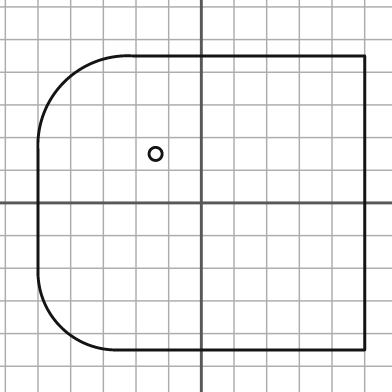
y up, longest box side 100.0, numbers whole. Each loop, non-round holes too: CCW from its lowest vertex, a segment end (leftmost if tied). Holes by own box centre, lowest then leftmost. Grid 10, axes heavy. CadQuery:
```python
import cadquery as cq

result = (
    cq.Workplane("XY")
    .moveTo(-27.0, -45.0)
    .lineTo(50.0, -45.0)
    .lineTo(50.0, 45.0)
    .lineTo(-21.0, 45.0)
    .threePointArc((-42.0, 37.0), (-50.0, 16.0))
    .lineTo(-50.0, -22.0)
    .threePointArc((-43.0, -38.0), (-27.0, -45.0))
    .close()
    .moveTo(-14.0, 15.0)
    .circle(2.0)
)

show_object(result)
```